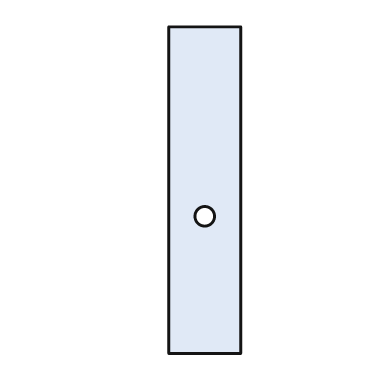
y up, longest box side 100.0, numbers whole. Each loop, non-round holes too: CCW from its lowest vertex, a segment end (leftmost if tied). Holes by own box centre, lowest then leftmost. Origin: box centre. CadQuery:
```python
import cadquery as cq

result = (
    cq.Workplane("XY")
    .moveTo(-11.0, -50.0)
    .lineTo(11.0, -50.0)
    .lineTo(11.0, 50.0)
    .lineTo(-11.0, 50.0)
    .close()
    .moveTo(0.0, -8.0)
    .circle(3.0)
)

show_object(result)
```